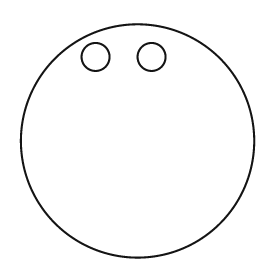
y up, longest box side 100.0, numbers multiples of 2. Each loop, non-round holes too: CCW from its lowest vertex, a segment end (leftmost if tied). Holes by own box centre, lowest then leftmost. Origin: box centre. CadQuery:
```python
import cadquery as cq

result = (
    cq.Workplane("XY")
    .moveTo(0.0, 0.0)
    .circle(50.0)
    .moveTo(-18.0, 36.0)
    .circle(6.0)
    .moveTo(6.0, 36.0)
    .circle(6.0)
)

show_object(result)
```